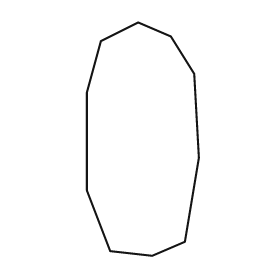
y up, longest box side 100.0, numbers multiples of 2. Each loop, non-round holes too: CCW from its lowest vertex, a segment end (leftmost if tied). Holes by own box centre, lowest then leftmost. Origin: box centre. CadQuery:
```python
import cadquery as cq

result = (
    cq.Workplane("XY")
    .moveTo(4.0, -50.0)
    .lineTo(18.0, -44.0)
    .lineTo(24.0, -8.0)
    .lineTo(22.0, 28.0)
    .lineTo(12.0, 44.0)
    .lineTo(-2.0, 50.0)
    .lineTo(-18.0, 42.0)
    .lineTo(-24.0, 20.0)
    .lineTo(-24.0, -22.0)
    .lineTo(-14.0, -48.0)
    .close()
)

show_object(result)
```